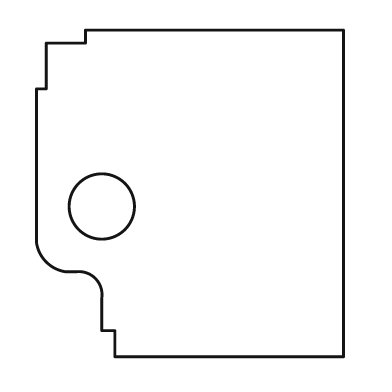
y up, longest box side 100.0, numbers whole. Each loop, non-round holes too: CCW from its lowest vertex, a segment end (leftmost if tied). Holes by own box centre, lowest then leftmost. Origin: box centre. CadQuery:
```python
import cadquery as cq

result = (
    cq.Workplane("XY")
    .moveTo(-23.0, -50.0)
    .lineTo(47.0, -50.0)
    .lineTo(47.0, 50.0)
    .lineTo(-32.0, 50.0)
    .lineTo(-32.0, 46.0)
    .lineTo(-44.0, 46.0)
    .lineTo(-44.0, 32.0)
    .lineTo(-47.0, 32.0)
    .lineTo(-47.0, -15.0)
    .threePointArc((-44.0, -21.0), (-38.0, -24.0))
    .lineTo(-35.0, -24.0)
    .threePointArc((-29.0, -26.0), (-27.0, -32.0))
    .lineTo(-27.0, -42.0)
    .lineTo(-23.0, -42.0)
    .close()
    .moveTo(-27.0, -4.0)
    .circle(10.0)
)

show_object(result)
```